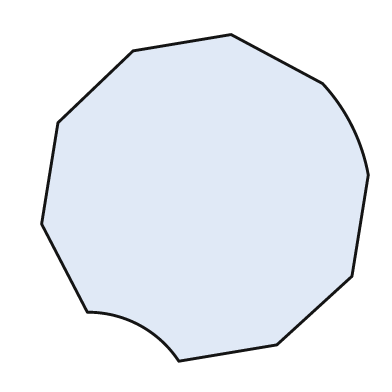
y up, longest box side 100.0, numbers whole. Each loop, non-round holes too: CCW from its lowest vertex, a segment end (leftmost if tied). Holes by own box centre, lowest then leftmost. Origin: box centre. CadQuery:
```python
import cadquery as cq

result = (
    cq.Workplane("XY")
    .moveTo(-8.0, -50.0)
    .lineTo(22.0, -45.0)
    .lineTo(45.0, -24.0)
    .lineTo(50.0, 7.0)
    .threePointArc((45.0, 22.0), (36.0, 35.0))
    .lineTo(8.0, 50.0)
    .lineTo(-22.0, 45.0)
    .lineTo(-45.0, 23.0)
    .lineTo(-50.0, -8.0)
    .lineTo(-36.0, -35.0)
    .threePointArc((-20.0, -39.0), (-8.0, -50.0))
    .close()
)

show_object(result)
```